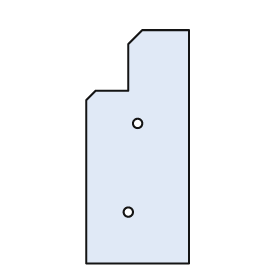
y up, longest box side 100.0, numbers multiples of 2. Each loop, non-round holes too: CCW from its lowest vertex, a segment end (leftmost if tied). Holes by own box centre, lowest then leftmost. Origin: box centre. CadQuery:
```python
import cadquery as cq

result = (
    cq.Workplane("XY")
    .moveTo(-22.0, -50.0)
    .lineTo(22.0, -50.0)
    .lineTo(22.0, 50.0)
    .lineTo(2.0, 50.0)
    .lineTo(-4.0, 44.0)
    .lineTo(-4.0, 24.0)
    .lineTo(-18.0, 24.0)
    .lineTo(-22.0, 20.0)
    .close()
    .moveTo(-4.0, -28.0)
    .circle(2.0)
    .moveTo(0.0, 10.0)
    .circle(2.0)
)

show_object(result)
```